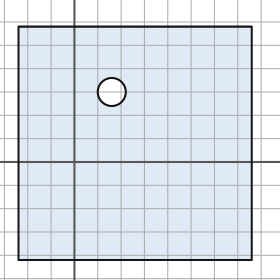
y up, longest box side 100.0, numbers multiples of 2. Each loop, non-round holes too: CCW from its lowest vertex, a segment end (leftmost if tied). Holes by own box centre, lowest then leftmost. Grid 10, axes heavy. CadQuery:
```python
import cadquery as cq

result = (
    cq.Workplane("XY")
    .moveTo(-24.0, -42.0)
    .lineTo(76.0, -42.0)
    .lineTo(76.0, 58.0)
    .lineTo(-24.0, 58.0)
    .close()
    .moveTo(16.0, 30.0)
    .circle(6.0)
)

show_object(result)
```